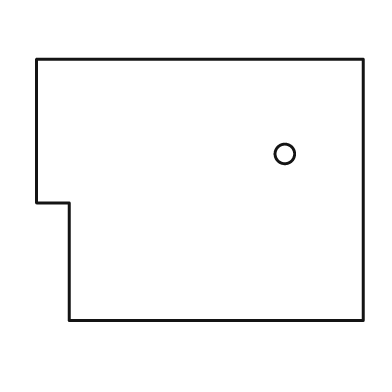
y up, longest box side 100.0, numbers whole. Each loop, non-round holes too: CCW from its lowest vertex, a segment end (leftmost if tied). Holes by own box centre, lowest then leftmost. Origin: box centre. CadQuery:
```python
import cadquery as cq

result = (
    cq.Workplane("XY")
    .moveTo(-40.0, -40.0)
    .lineTo(50.0, -40.0)
    .lineTo(50.0, 40.0)
    .lineTo(-50.0, 40.0)
    .lineTo(-50.0, -4.0)
    .lineTo(-40.0, -4.0)
    .close()
    .moveTo(26.0, 11.0)
    .circle(3.0)
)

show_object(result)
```